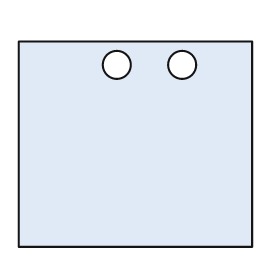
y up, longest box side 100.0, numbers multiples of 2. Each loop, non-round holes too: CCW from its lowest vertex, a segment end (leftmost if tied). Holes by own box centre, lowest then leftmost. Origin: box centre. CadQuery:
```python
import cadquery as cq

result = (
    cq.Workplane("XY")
    .moveTo(-50.0, -44.0)
    .lineTo(50.0, -44.0)
    .lineTo(50.0, 44.0)
    .lineTo(-50.0, 44.0)
    .close()
    .moveTo(-8.0, 34.0)
    .circle(6.0)
    .moveTo(20.0, 34.0)
    .circle(6.0)
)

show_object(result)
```